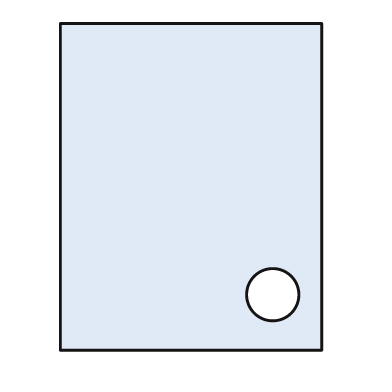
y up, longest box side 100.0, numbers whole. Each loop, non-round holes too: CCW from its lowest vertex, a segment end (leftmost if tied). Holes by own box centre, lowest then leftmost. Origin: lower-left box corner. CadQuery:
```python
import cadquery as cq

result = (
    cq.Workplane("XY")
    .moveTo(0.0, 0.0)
    .lineTo(80.0, 0.0)
    .lineTo(80.0, 100.0)
    .lineTo(0.0, 100.0)
    .close()
    .moveTo(65.0, 17.0)
    .circle(8.0)
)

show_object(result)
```